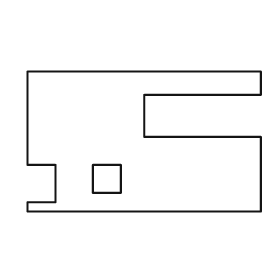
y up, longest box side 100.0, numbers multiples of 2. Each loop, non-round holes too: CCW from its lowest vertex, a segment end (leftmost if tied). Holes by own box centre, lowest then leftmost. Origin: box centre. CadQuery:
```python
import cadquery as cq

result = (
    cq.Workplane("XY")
    .moveTo(-50.0, -30.0)
    .lineTo(50.0, -30.0)
    .lineTo(50.0, 2.0)
    .lineTo(0.0, 2.0)
    .lineTo(0.0, 20.0)
    .lineTo(50.0, 20.0)
    .lineTo(50.0, 30.0)
    .lineTo(-50.0, 30.0)
    .lineTo(-50.0, -10.0)
    .lineTo(-38.0, -10.0)
    .lineTo(-38.0, -26.0)
    .lineTo(-50.0, -26.0)
    .close()
    .moveTo(-22.0, -22.0)
    .lineTo(-10.0, -22.0)
    .lineTo(-10.0, -10.0)
    .lineTo(-22.0, -10.0)
    .close()
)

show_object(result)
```